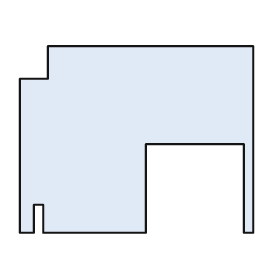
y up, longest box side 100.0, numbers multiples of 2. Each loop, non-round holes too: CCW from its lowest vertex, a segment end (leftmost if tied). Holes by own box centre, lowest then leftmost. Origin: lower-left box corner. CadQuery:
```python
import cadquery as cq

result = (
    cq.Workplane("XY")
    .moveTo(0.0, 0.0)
    .lineTo(6.0, 0.0)
    .lineTo(6.0, 12.0)
    .lineTo(10.0, 12.0)
    .lineTo(10.0, 0.0)
    .lineTo(54.0, 0.0)
    .lineTo(54.0, 38.0)
    .lineTo(96.0, 38.0)
    .lineTo(96.0, 0.0)
    .lineTo(100.0, 0.0)
    .lineTo(100.0, 80.0)
    .lineTo(12.0, 80.0)
    .lineTo(12.0, 66.0)
    .lineTo(0.0, 66.0)
    .close()
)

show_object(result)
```